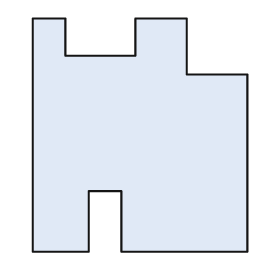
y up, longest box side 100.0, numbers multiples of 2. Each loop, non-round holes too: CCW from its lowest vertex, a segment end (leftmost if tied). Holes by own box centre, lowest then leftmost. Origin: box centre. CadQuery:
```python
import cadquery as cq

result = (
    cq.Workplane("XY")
    .moveTo(-46.0, -50.0)
    .lineTo(-22.0, -50.0)
    .lineTo(-22.0, -24.0)
    .lineTo(-8.0, -24.0)
    .lineTo(-8.0, -50.0)
    .lineTo(46.0, -50.0)
    .lineTo(46.0, 26.0)
    .lineTo(20.0, 26.0)
    .lineTo(20.0, 50.0)
    .lineTo(-2.0, 50.0)
    .lineTo(-2.0, 34.0)
    .lineTo(-32.0, 34.0)
    .lineTo(-32.0, 50.0)
    .lineTo(-46.0, 50.0)
    .close()
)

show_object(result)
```